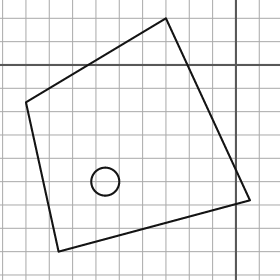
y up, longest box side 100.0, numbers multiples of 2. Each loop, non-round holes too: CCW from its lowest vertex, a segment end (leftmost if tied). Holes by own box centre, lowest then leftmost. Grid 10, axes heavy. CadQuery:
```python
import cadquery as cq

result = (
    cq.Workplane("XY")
    .moveTo(-76.0, -80.0)
    .lineTo(6.0, -58.0)
    .lineTo(-30.0, 20.0)
    .lineTo(-90.0, -16.0)
    .close()
    .moveTo(-56.0, -50.0)
    .circle(6.0)
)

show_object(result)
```